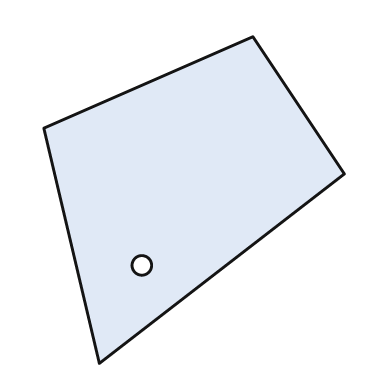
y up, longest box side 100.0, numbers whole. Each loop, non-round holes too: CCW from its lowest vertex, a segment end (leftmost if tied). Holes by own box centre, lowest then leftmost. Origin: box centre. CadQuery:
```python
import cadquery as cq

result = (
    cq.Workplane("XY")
    .moveTo(-29.0, -50.0)
    .lineTo(46.0, 8.0)
    .lineTo(18.0, 50.0)
    .lineTo(-46.0, 22.0)
    .close()
    .moveTo(-16.0, -20.0)
    .circle(3.0)
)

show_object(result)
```